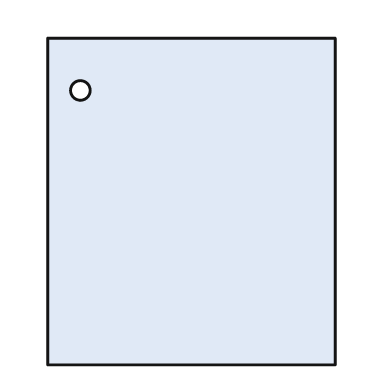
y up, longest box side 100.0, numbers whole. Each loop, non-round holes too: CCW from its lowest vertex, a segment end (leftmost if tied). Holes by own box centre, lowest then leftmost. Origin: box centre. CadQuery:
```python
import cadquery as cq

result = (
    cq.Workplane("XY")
    .moveTo(-44.0, -50.0)
    .lineTo(44.0, -50.0)
    .lineTo(44.0, 50.0)
    .lineTo(-44.0, 50.0)
    .close()
    .moveTo(-34.0, 34.0)
    .circle(3.0)
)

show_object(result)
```